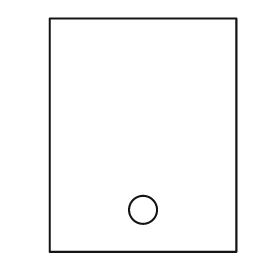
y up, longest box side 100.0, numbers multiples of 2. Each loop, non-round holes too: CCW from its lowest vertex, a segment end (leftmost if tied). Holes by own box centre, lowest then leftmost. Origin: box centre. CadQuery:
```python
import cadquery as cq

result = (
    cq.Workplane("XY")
    .moveTo(-40.0, -50.0)
    .lineTo(40.0, -50.0)
    .lineTo(40.0, 50.0)
    .lineTo(-40.0, 50.0)
    .close()
    .moveTo(0.0, -32.0)
    .circle(6.0)
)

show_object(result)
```